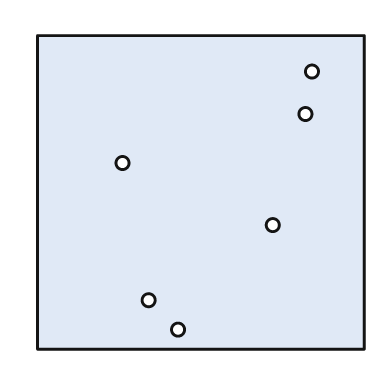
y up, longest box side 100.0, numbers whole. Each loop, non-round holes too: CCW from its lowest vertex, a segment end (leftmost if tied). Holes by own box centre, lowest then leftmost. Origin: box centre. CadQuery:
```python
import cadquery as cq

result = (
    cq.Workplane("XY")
    .moveTo(-50.0, -48.0)
    .lineTo(50.0, -48.0)
    .lineTo(50.0, 48.0)
    .lineTo(-50.0, 48.0)
    .close()
    .moveTo(-7.0, -42.0)
    .circle(2.0)
    .moveTo(-16.0, -33.0)
    .circle(2.0)
    .moveTo(22.0, -10.0)
    .circle(2.0)
    .moveTo(-24.0, 9.0)
    .circle(2.0)
    .moveTo(32.0, 24.0)
    .circle(2.0)
    .moveTo(34.0, 37.0)
    .circle(2.0)
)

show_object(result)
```